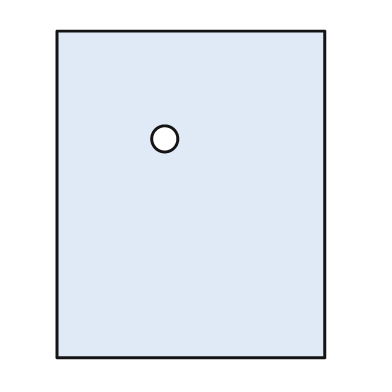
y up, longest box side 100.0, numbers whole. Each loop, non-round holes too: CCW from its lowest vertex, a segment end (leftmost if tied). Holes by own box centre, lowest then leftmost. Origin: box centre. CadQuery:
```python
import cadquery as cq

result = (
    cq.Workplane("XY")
    .moveTo(-41.0, -50.0)
    .lineTo(41.0, -50.0)
    .lineTo(41.0, 50.0)
    .lineTo(-41.0, 50.0)
    .close()
    .moveTo(-8.0, 17.0)
    .circle(4.0)
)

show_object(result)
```